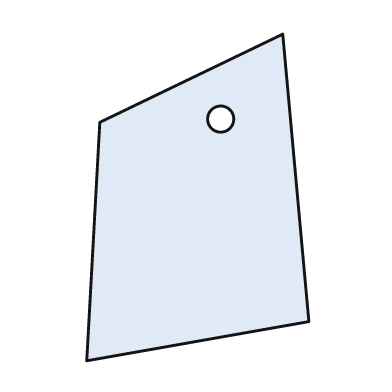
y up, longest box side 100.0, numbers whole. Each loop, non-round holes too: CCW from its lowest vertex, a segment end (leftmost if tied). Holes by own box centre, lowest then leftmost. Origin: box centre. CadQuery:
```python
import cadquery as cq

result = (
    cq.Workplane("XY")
    .moveTo(-34.0, -50.0)
    .lineTo(34.0, -38.0)
    .lineTo(26.0, 50.0)
    .lineTo(-30.0, 23.0)
    .close()
    .moveTo(7.0, 24.0)
    .circle(4.0)
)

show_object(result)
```